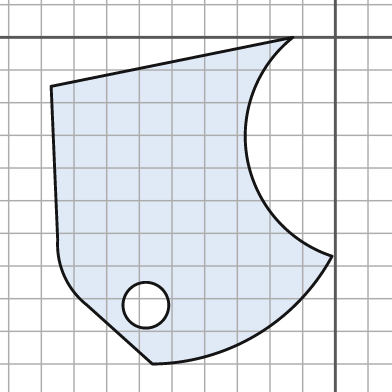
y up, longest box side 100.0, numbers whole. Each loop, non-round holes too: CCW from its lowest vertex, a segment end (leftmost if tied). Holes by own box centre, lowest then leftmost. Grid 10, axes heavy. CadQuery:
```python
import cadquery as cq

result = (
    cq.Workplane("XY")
    .moveTo(-56.0, -100.0)
    .threePointArc((-24.0, -91.0), (-1.0, -67.0))
    .threePointArc((-27.0, -37.0), (-13.0, 0.0))
    .lineTo(-87.0, -15.0)
    .lineTo(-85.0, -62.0)
    .threePointArc((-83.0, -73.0), (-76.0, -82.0))
    .close()
    .moveTo(-58.0, -82.0)
    .circle(7.0)
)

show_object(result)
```